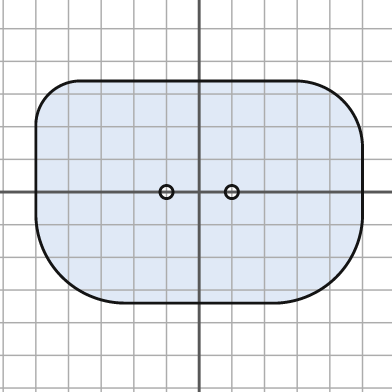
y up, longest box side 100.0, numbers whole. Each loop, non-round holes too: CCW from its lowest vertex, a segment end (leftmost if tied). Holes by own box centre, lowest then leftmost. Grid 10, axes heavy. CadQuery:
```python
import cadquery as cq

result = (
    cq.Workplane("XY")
    .moveTo(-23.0, -34.0)
    .lineTo(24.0, -34.0)
    .threePointArc((42.0, -26.0), (50.0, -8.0))
    .lineTo(50.0, 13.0)
    .threePointArc((44.0, 28.0), (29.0, 34.0))
    .lineTo(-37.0, 34.0)
    .threePointArc((-46.0, 30.0), (-50.0, 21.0))
    .lineTo(-50.0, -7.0)
    .threePointArc((-42.0, -26.0), (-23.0, -34.0))
    .close()
    .moveTo(-10.0, 0.0)
    .circle(2.0)
    .moveTo(10.0, 0.0)
    .circle(2.0)
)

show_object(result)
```